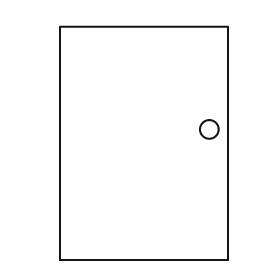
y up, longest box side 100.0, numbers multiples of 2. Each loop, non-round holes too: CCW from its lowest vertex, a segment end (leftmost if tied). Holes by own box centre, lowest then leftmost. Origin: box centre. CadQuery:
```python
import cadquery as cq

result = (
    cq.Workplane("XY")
    .moveTo(-36.0, -50.0)
    .lineTo(36.0, -50.0)
    .lineTo(36.0, 50.0)
    .lineTo(-36.0, 50.0)
    .close()
    .moveTo(28.0, 6.0)
    .circle(4.0)
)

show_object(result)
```